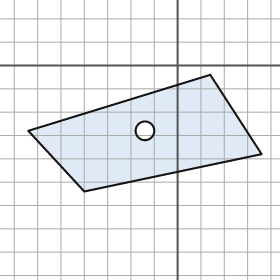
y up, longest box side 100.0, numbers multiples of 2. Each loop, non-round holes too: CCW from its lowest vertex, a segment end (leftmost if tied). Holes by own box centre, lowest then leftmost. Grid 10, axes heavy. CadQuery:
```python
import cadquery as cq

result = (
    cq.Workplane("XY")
    .moveTo(-40.0, -54.0)
    .lineTo(36.0, -38.0)
    .lineTo(14.0, -4.0)
    .lineTo(-64.0, -28.0)
    .close()
    .moveTo(-14.0, -28.0)
    .circle(4.0)
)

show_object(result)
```